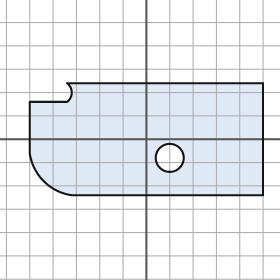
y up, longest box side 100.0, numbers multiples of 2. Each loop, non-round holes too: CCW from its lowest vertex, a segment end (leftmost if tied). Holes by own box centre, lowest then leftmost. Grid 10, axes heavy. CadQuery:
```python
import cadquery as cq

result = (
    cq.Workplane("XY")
    .moveTo(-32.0, -24.0)
    .lineTo(50.0, -24.0)
    .lineTo(50.0, 24.0)
    .lineTo(-34.0, 24.0)
    .threePointArc((-32.0, 20.0), (-34.0, 16.0))
    .lineTo(-50.0, 16.0)
    .lineTo(-50.0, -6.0)
    .threePointArc((-44.0, -18.0), (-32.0, -24.0))
    .close()
    .moveTo(10.0, -8.0)
    .circle(6.0)
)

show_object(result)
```